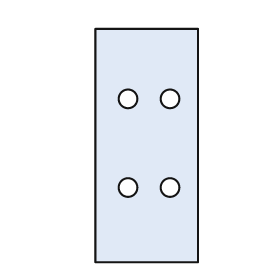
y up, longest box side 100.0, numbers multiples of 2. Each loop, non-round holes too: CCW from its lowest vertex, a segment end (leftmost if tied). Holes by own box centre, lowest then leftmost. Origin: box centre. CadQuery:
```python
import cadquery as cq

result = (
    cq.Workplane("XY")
    .moveTo(-22.0, -50.0)
    .lineTo(22.0, -50.0)
    .lineTo(22.0, 50.0)
    .lineTo(-22.0, 50.0)
    .close()
    .moveTo(-8.0, -18.0)
    .circle(4.0)
    .moveTo(10.0, -18.0)
    .circle(4.0)
    .moveTo(-8.0, 20.0)
    .circle(4.0)
    .moveTo(10.0, 20.0)
    .circle(4.0)
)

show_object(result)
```